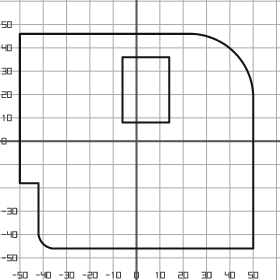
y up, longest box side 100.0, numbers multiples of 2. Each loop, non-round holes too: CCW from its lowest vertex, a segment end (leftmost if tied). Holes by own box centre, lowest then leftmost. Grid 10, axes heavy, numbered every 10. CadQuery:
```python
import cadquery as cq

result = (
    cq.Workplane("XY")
    .moveTo(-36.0, -46.0)
    .lineTo(50.0, -46.0)
    .lineTo(50.0, 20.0)
    .threePointArc((42.0, 38.0), (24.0, 46.0))
    .lineTo(-50.0, 46.0)
    .lineTo(-50.0, -18.0)
    .lineTo(-42.0, -18.0)
    .lineTo(-42.0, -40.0)
    .threePointArc((-40.0, -44.0), (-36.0, -46.0))
    .close()
    .moveTo(-6.0, 8.0)
    .lineTo(14.0, 8.0)
    .lineTo(14.0, 36.0)
    .lineTo(-6.0, 36.0)
    .close()
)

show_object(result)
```